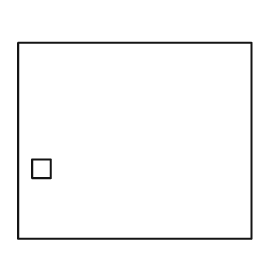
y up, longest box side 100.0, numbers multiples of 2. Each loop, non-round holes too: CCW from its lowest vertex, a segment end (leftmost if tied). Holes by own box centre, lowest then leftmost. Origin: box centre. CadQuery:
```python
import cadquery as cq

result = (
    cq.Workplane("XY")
    .moveTo(-50.0, -42.0)
    .lineTo(50.0, -42.0)
    .lineTo(50.0, 42.0)
    .lineTo(-50.0, 42.0)
    .close()
    .moveTo(-44.0, -16.0)
    .lineTo(-36.0, -16.0)
    .lineTo(-36.0, -8.0)
    .lineTo(-44.0, -8.0)
    .close()
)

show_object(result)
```